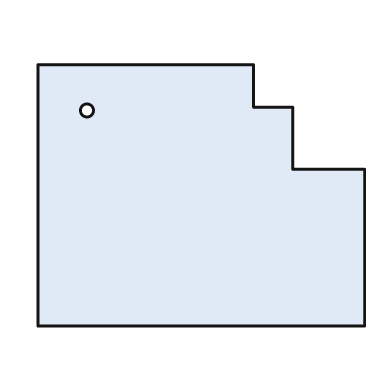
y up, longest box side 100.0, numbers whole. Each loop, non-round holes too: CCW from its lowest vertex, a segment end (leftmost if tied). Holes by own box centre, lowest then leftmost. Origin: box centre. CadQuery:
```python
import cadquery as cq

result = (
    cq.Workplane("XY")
    .moveTo(-50.0, -40.0)
    .lineTo(50.0, -40.0)
    .lineTo(50.0, 8.0)
    .lineTo(28.0, 8.0)
    .lineTo(28.0, 27.0)
    .lineTo(16.0, 27.0)
    .lineTo(16.0, 40.0)
    .lineTo(-50.0, 40.0)
    .close()
    .moveTo(-35.0, 26.0)
    .circle(2.0)
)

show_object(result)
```